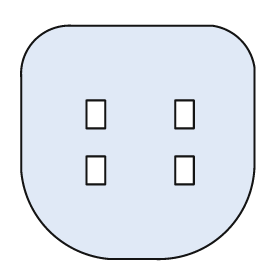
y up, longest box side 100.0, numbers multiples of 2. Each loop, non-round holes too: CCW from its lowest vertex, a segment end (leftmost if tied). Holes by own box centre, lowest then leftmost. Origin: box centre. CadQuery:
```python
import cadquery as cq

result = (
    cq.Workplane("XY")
    .moveTo(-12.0, -50.0)
    .lineTo(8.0, -50.0)
    .threePointArc((38.0, -38.0), (50.0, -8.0))
    .lineTo(50.0, 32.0)
    .threePointArc((44.0, 44.0), (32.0, 50.0))
    .lineTo(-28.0, 50.0)
    .threePointArc((-44.0, 44.0), (-50.0, 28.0))
    .lineTo(-50.0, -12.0)
    .threePointArc((-38.0, -38.0), (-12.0, -50.0))
    .close()
    .moveTo(-22.0, -18.0)
    .lineTo(-14.0, -18.0)
    .lineTo(-14.0, -6.0)
    .lineTo(-22.0, -6.0)
    .close()
    .moveTo(16.0, -18.0)
    .lineTo(24.0, -18.0)
    .lineTo(24.0, -6.0)
    .lineTo(16.0, -6.0)
    .close()
    .moveTo(-22.0, 6.0)
    .lineTo(-14.0, 6.0)
    .lineTo(-14.0, 18.0)
    .lineTo(-22.0, 18.0)
    .close()
    .moveTo(16.0, 6.0)
    .lineTo(24.0, 6.0)
    .lineTo(24.0, 18.0)
    .lineTo(16.0, 18.0)
    .close()
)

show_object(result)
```